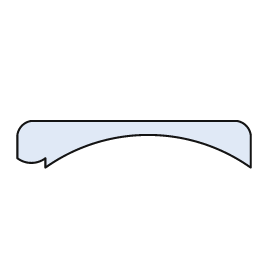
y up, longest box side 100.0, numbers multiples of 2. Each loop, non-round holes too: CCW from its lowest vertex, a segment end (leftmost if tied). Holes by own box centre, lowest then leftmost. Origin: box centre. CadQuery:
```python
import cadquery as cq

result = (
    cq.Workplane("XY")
    .moveTo(-38.0, -10.0)
    .threePointArc((6.0, 4.0), (50.0, -10.0))
    .lineTo(50.0, 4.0)
    .threePointArc((48.0, 8.0), (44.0, 10.0))
    .lineTo(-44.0, 10.0)
    .threePointArc((-48.0, 8.0), (-50.0, 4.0))
    .lineTo(-50.0, -6.0)
    .threePointArc((-44.0, -8.0), (-38.0, -6.0))
    .close()
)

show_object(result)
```